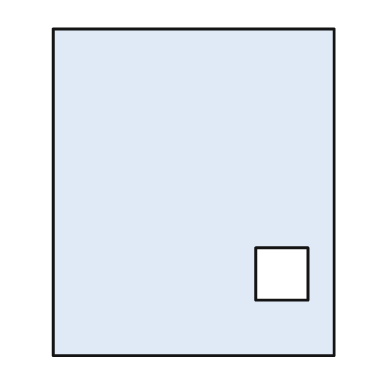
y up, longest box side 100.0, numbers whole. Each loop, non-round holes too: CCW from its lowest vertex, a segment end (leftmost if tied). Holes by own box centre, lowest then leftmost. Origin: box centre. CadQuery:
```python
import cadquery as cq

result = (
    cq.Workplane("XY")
    .moveTo(-43.0, -50.0)
    .lineTo(43.0, -50.0)
    .lineTo(43.0, 50.0)
    .lineTo(-43.0, 50.0)
    .close()
    .moveTo(19.0, -33.0)
    .lineTo(35.0, -33.0)
    .lineTo(35.0, -17.0)
    .lineTo(19.0, -17.0)
    .close()
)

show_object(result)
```